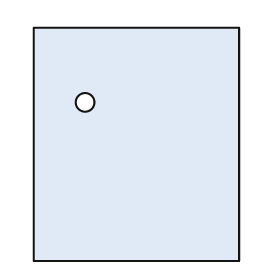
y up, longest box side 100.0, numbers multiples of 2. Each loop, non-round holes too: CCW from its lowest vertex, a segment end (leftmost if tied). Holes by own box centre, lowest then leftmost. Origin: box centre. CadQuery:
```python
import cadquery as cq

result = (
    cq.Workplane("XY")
    .moveTo(-44.0, -50.0)
    .lineTo(44.0, -50.0)
    .lineTo(44.0, 50.0)
    .lineTo(-44.0, 50.0)
    .close()
    .moveTo(-22.0, 18.0)
    .circle(4.0)
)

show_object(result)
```